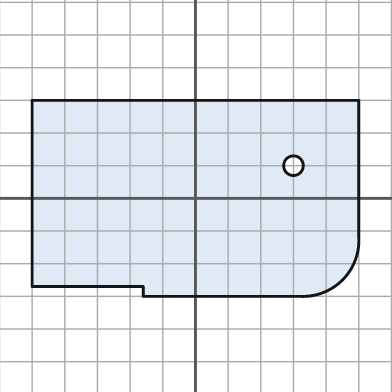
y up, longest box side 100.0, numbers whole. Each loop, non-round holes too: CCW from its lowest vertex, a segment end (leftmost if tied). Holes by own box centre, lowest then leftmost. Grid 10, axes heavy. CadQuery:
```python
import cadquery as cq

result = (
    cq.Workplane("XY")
    .moveTo(-16.0, -30.0)
    .lineTo(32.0, -30.0)
    .threePointArc((45.0, -25.0), (50.0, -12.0))
    .lineTo(50.0, 30.0)
    .lineTo(-50.0, 30.0)
    .lineTo(-50.0, -27.0)
    .lineTo(-16.0, -27.0)
    .close()
    .moveTo(30.0, 10.0)
    .circle(3.0)
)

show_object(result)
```